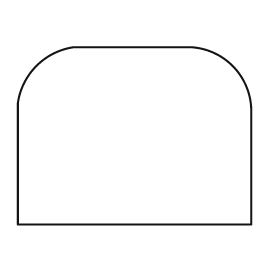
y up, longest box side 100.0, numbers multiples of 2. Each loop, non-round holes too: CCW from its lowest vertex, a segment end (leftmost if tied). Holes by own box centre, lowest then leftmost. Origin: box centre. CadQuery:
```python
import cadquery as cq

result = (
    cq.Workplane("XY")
    .moveTo(-50.0, -38.0)
    .lineTo(50.0, -38.0)
    .lineTo(50.0, 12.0)
    .threePointArc((42.0, 30.0), (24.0, 38.0))
    .lineTo(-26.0, 38.0)
    .threePointArc((-42.0, 30.0), (-50.0, 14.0))
    .close()
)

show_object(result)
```